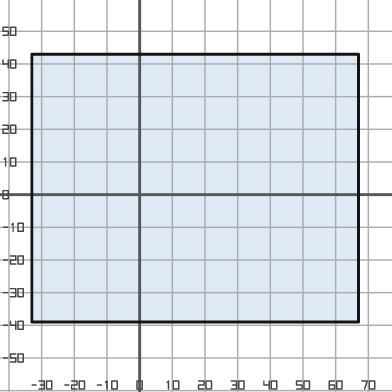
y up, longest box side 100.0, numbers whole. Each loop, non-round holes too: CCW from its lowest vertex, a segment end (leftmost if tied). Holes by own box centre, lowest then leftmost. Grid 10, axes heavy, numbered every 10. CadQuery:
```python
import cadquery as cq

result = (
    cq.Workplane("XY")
    .moveTo(-33.0, -39.0)
    .lineTo(67.0, -39.0)
    .lineTo(67.0, 43.0)
    .lineTo(-33.0, 43.0)
    .close()
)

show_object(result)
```